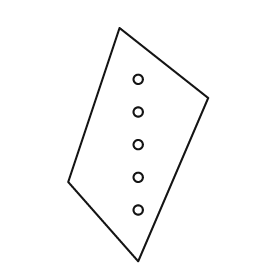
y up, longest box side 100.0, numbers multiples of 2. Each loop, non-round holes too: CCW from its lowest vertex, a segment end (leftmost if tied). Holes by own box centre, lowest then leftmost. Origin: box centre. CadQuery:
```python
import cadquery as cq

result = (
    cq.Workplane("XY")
    .moveTo(0.0, -50.0)
    .lineTo(30.0, 20.0)
    .lineTo(-8.0, 50.0)
    .lineTo(-30.0, -16.0)
    .close()
    .moveTo(0.0, -28.0)
    .circle(2.0)
    .moveTo(0.0, -14.0)
    .circle(2.0)
    .moveTo(0.0, 0.0)
    .circle(2.0)
    .moveTo(0.0, 14.0)
    .circle(2.0)
    .moveTo(0.0, 28.0)
    .circle(2.0)
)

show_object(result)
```